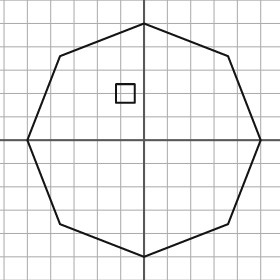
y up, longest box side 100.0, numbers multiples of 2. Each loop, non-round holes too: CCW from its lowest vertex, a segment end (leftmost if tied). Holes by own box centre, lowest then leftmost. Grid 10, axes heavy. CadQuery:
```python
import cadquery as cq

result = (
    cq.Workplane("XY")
    .moveTo(0.0, -50.0)
    .lineTo(36.0, -36.0)
    .lineTo(50.0, 0.0)
    .lineTo(36.0, 36.0)
    .lineTo(0.0, 50.0)
    .lineTo(-36.0, 36.0)
    .lineTo(-50.0, 0.0)
    .lineTo(-36.0, -36.0)
    .close()
    .moveTo(-12.0, 16.0)
    .lineTo(-4.0, 16.0)
    .lineTo(-4.0, 24.0)
    .lineTo(-12.0, 24.0)
    .close()
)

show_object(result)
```